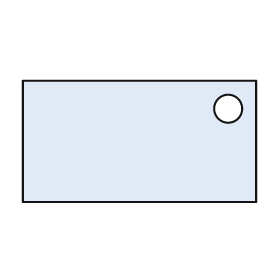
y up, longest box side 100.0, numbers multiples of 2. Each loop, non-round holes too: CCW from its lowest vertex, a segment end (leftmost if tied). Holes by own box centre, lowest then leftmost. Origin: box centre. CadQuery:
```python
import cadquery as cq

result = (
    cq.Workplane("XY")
    .moveTo(-50.0, -26.0)
    .lineTo(50.0, -26.0)
    .lineTo(50.0, 26.0)
    .lineTo(-50.0, 26.0)
    .close()
    .moveTo(38.0, 14.0)
    .circle(6.0)
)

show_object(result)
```